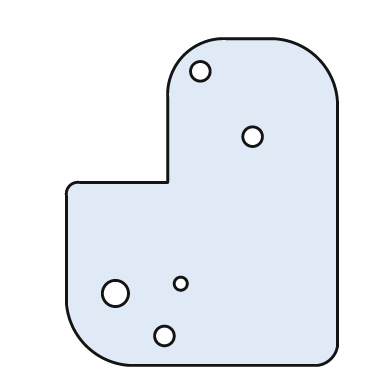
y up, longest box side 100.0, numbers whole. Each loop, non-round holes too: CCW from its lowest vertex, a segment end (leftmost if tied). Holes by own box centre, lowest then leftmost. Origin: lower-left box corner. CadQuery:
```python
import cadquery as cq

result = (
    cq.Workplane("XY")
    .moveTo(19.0, 0.0)
    .lineTo(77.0, 0.0)
    .threePointArc((81.0, 2.0), (83.0, 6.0))
    .lineTo(83.0, 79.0)
    .threePointArc((77.0, 94.0), (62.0, 100.0))
    .lineTo(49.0, 100.0)
    .threePointArc((36.0, 95.0), (31.0, 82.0))
    .lineTo(31.0, 56.0)
    .lineTo(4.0, 56.0)
    .threePointArc((1.0, 55.0), (0.0, 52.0))
    .lineTo(0.0, 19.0)
    .threePointArc((6.0, 6.0), (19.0, 0.0))
    .close()
    .moveTo(30.0, 9.0)
    .circle(3.0)
    .moveTo(15.0, 22.0)
    .circle(4.0)
    .moveTo(35.0, 25.0)
    .circle(2.0)
    .moveTo(57.0, 70.0)
    .circle(3.0)
    .moveTo(41.0, 90.0)
    .circle(3.0)
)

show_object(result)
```